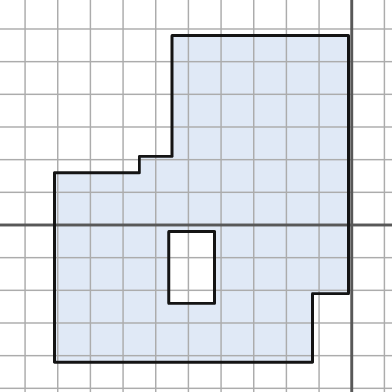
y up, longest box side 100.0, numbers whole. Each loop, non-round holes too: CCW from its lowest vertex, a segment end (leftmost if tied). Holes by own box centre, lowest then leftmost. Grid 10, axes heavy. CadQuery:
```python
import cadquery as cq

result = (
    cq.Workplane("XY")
    .moveTo(-91.0, -42.0)
    .lineTo(-12.0, -42.0)
    .lineTo(-12.0, -21.0)
    .lineTo(-1.0, -21.0)
    .lineTo(-1.0, 58.0)
    .lineTo(-55.0, 58.0)
    .lineTo(-55.0, 21.0)
    .lineTo(-65.0, 21.0)
    .lineTo(-65.0, 16.0)
    .lineTo(-91.0, 16.0)
    .close()
    .moveTo(-56.0, -24.0)
    .lineTo(-42.0, -24.0)
    .lineTo(-42.0, -2.0)
    .lineTo(-56.0, -2.0)
    .close()
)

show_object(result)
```